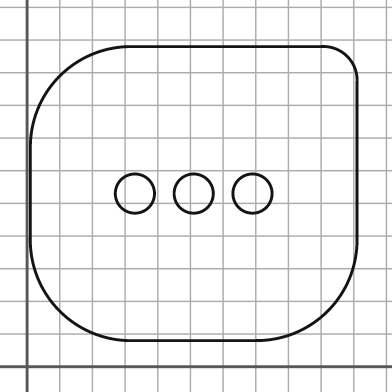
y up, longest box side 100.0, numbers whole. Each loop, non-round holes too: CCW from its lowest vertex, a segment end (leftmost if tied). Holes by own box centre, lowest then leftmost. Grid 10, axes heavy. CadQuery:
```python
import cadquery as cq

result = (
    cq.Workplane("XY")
    .moveTo(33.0, 8.0)
    .lineTo(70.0, 8.0)
    .threePointArc((92.0, 17.0), (101.0, 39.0))
    .lineTo(101.0, 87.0)
    .threePointArc((98.0, 95.0), (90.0, 98.0))
    .lineTo(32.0, 98.0)
    .threePointArc((10.0, 89.0), (1.0, 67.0))
    .lineTo(1.0, 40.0)
    .threePointArc((10.0, 17.0), (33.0, 8.0))
    .close()
    .moveTo(33.0, 53.0)
    .circle(6.0)
    .moveTo(51.0, 53.0)
    .circle(6.0)
    .moveTo(69.0, 53.0)
    .circle(6.0)
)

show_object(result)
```